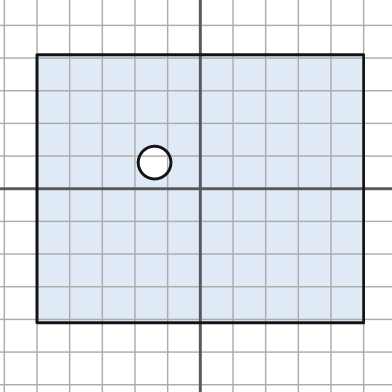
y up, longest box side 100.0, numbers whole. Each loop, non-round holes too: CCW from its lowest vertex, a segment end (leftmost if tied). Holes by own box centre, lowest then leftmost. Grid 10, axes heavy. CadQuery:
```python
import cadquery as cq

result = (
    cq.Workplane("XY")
    .moveTo(-50.0, -41.0)
    .lineTo(50.0, -41.0)
    .lineTo(50.0, 41.0)
    .lineTo(-50.0, 41.0)
    .close()
    .moveTo(-14.0, 8.0)
    .circle(5.0)
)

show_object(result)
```